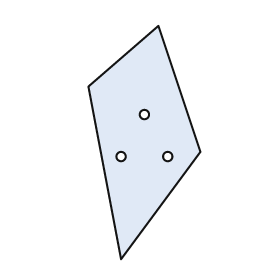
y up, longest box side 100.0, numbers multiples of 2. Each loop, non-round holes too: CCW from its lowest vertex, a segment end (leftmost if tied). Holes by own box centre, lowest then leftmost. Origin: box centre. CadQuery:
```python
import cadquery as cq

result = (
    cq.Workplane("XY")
    .moveTo(-10.0, -50.0)
    .lineTo(24.0, -4.0)
    .lineTo(6.0, 50.0)
    .lineTo(-24.0, 24.0)
    .close()
    .moveTo(-10.0, -6.0)
    .circle(2.0)
    .moveTo(10.0, -6.0)
    .circle(2.0)
    .moveTo(0.0, 12.0)
    .circle(2.0)
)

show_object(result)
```